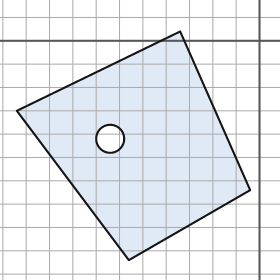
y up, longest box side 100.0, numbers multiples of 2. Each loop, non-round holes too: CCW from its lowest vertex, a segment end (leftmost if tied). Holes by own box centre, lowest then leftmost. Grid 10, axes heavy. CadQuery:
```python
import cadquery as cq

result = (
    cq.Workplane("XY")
    .moveTo(-56.0, -94.0)
    .lineTo(-4.0, -64.0)
    .lineTo(-34.0, 4.0)
    .lineTo(-104.0, -30.0)
    .close()
    .moveTo(-64.0, -42.0)
    .circle(6.0)
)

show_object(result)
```